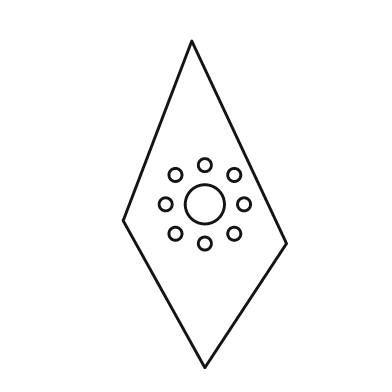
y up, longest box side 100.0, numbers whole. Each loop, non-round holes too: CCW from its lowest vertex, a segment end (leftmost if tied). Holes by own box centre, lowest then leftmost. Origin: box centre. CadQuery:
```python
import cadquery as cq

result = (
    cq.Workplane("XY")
    .moveTo(0.0, -50.0)
    .lineTo(25.0, -12.0)
    .lineTo(-4.0, 50.0)
    .lineTo(-25.0, -5.0)
    .close()
    .moveTo(0.0, -12.0)
    .circle(2.0)
    .moveTo(-9.0, -9.0)
    .circle(2.0)
    .moveTo(9.0, -9.0)
    .circle(2.0)
    .moveTo(-12.0, 0.0)
    .circle(2.0)
    .moveTo(0.0, 0.0)
    .circle(6.0)
    .moveTo(12.0, 0.0)
    .circle(2.0)
    .moveTo(-9.0, 9.0)
    .circle(2.0)
    .moveTo(9.0, 9.0)
    .circle(2.0)
    .moveTo(0.0, 12.0)
    .circle(2.0)
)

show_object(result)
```